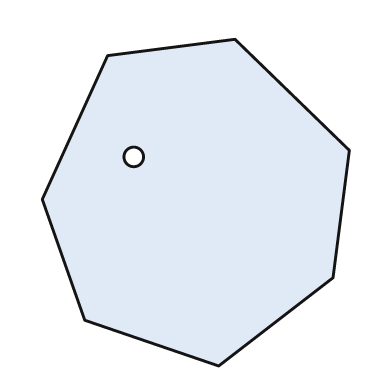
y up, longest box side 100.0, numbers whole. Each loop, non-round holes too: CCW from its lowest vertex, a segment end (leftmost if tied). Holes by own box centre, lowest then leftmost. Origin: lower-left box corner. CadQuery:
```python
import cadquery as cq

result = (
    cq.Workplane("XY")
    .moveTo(54.0, 0.0)
    .lineTo(89.0, 27.0)
    .lineTo(94.0, 66.0)
    .lineTo(59.0, 100.0)
    .lineTo(20.0, 95.0)
    .lineTo(0.0, 51.0)
    .lineTo(13.0, 14.0)
    .close()
    .moveTo(28.0, 64.0)
    .circle(3.0)
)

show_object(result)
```